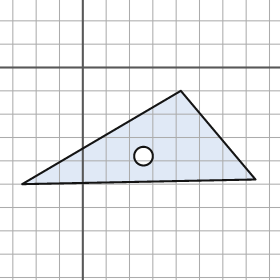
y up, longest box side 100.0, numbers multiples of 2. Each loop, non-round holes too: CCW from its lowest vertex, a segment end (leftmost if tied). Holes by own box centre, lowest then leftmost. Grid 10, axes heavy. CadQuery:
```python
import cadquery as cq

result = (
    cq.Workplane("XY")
    .moveTo(-26.0, -50.0)
    .lineTo(74.0, -48.0)
    .lineTo(42.0, -10.0)
    .close()
    .moveTo(26.0, -38.0)
    .circle(4.0)
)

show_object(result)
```